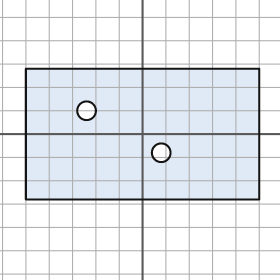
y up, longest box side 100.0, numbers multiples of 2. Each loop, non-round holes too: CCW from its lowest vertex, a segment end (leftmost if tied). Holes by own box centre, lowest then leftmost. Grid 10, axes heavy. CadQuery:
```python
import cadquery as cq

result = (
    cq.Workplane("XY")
    .moveTo(-50.0, -28.0)
    .lineTo(50.0, -28.0)
    .lineTo(50.0, 28.0)
    .lineTo(-50.0, 28.0)
    .close()
    .moveTo(8.0, -8.0)
    .circle(4.0)
    .moveTo(-24.0, 10.0)
    .circle(4.0)
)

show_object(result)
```